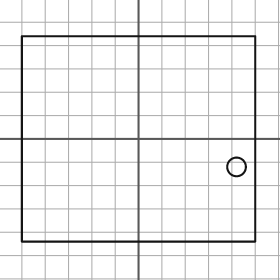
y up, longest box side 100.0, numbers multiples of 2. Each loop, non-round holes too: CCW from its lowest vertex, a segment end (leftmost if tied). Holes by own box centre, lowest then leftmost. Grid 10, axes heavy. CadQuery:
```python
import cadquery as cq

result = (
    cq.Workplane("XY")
    .moveTo(-50.0, -44.0)
    .lineTo(50.0, -44.0)
    .lineTo(50.0, 44.0)
    .lineTo(-50.0, 44.0)
    .close()
    .moveTo(42.0, -12.0)
    .circle(4.0)
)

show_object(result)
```